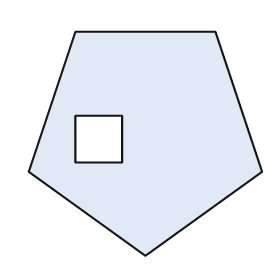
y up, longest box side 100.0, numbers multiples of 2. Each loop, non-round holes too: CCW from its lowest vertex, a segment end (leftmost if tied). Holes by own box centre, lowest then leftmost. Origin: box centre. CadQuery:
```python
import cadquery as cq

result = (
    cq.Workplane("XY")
    .moveTo(0.0, -48.0)
    .lineTo(50.0, -12.0)
    .lineTo(30.0, 48.0)
    .lineTo(-30.0, 48.0)
    .lineTo(-50.0, -12.0)
    .close()
    .moveTo(-30.0, -8.0)
    .lineTo(-10.0, -8.0)
    .lineTo(-10.0, 12.0)
    .lineTo(-30.0, 12.0)
    .close()
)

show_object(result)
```